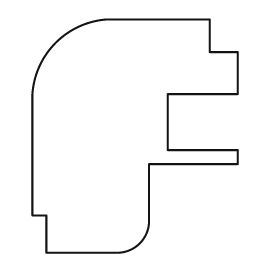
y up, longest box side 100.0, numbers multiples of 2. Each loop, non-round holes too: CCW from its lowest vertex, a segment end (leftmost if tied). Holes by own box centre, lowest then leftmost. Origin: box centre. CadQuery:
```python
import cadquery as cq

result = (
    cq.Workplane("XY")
    .moveTo(-38.0, -50.0)
    .lineTo(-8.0, -50.0)
    .threePointArc((2.0, -46.0), (6.0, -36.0))
    .lineTo(6.0, -12.0)
    .lineTo(44.0, -12.0)
    .lineTo(44.0, -6.0)
    .lineTo(14.0, -6.0)
    .lineTo(14.0, 18.0)
    .lineTo(44.0, 18.0)
    .lineTo(44.0, 36.0)
    .lineTo(32.0, 36.0)
    .lineTo(32.0, 50.0)
    .lineTo(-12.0, 50.0)
    .threePointArc((-34.0, 40.0), (-44.0, 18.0))
    .lineTo(-44.0, -34.0)
    .lineTo(-38.0, -34.0)
    .close()
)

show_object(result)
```